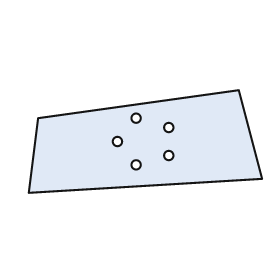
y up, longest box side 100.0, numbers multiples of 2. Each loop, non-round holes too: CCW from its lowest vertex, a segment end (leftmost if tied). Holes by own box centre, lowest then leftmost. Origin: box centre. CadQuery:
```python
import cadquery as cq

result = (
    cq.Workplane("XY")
    .moveTo(-50.0, -22.0)
    .lineTo(50.0, -16.0)
    .lineTo(40.0, 22.0)
    .lineTo(-46.0, 10.0)
    .close()
    .moveTo(-4.0, -10.0)
    .circle(2.0)
    .moveTo(10.0, -6.0)
    .circle(2.0)
    .moveTo(-12.0, 0.0)
    .circle(2.0)
    .moveTo(10.0, 6.0)
    .circle(2.0)
    .moveTo(-4.0, 10.0)
    .circle(2.0)
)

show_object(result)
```